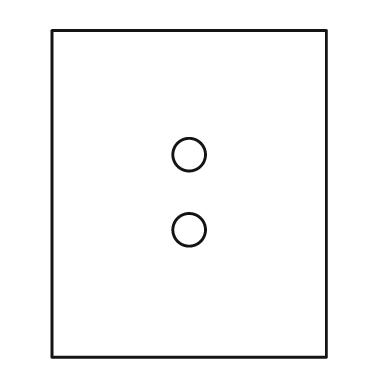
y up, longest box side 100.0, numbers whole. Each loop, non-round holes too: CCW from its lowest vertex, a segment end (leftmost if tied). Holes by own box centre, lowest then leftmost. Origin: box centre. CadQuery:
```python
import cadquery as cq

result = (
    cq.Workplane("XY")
    .moveTo(-42.0, -50.0)
    .lineTo(42.0, -50.0)
    .lineTo(42.0, 50.0)
    .lineTo(-42.0, 50.0)
    .close()
    .moveTo(0.0, -11.0)
    .circle(5.0)
    .moveTo(0.0, 12.0)
    .circle(5.0)
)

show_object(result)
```